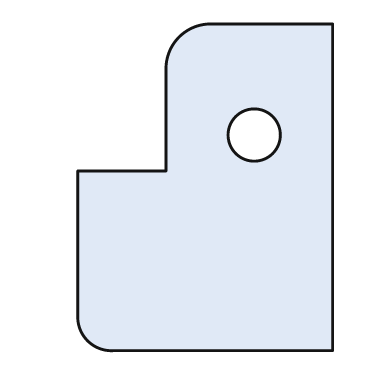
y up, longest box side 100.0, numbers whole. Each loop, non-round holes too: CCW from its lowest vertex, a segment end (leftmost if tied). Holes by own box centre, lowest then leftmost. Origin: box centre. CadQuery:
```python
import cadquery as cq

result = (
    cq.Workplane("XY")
    .moveTo(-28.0, -50.0)
    .lineTo(39.0, -50.0)
    .lineTo(39.0, 50.0)
    .lineTo(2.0, 50.0)
    .threePointArc((-8.0, 46.0), (-12.0, 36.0))
    .lineTo(-12.0, 5.0)
    .lineTo(-39.0, 5.0)
    .lineTo(-39.0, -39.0)
    .threePointArc((-36.0, -47.0), (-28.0, -50.0))
    .close()
    .moveTo(15.0, 16.0)
    .circle(8.0)
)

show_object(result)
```